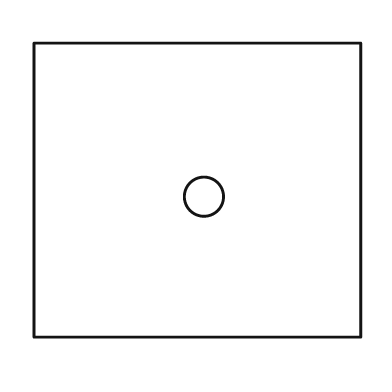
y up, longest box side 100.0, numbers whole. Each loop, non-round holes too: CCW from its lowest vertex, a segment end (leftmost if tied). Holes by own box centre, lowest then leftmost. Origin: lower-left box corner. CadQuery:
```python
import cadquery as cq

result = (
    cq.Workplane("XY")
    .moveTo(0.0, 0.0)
    .lineTo(100.0, 0.0)
    .lineTo(100.0, 90.0)
    .lineTo(0.0, 90.0)
    .close()
    .moveTo(52.0, 43.0)
    .circle(6.0)
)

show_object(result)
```